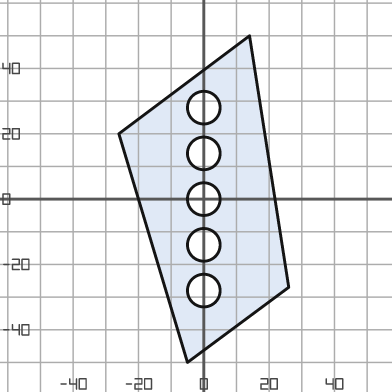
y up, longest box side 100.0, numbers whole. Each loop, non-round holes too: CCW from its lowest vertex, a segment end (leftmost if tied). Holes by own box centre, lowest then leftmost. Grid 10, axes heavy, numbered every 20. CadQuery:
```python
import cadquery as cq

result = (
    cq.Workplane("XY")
    .moveTo(-5.0, -50.0)
    .lineTo(26.0, -27.0)
    .lineTo(14.0, 50.0)
    .lineTo(-26.0, 20.0)
    .close()
    .moveTo(0.0, -28.0)
    .circle(5.0)
    .moveTo(0.0, -14.0)
    .circle(5.0)
    .moveTo(0.0, 0.0)
    .circle(5.0)
    .moveTo(0.0, 14.0)
    .circle(5.0)
    .moveTo(0.0, 28.0)
    .circle(5.0)
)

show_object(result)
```